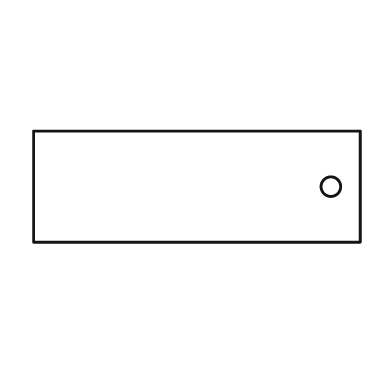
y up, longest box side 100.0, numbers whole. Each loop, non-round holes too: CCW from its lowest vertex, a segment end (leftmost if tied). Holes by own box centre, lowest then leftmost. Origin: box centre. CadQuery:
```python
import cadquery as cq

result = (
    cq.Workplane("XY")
    .moveTo(-50.0, -17.0)
    .lineTo(50.0, -17.0)
    .lineTo(50.0, 17.0)
    .lineTo(-50.0, 17.0)
    .close()
    .moveTo(41.0, 0.0)
    .circle(3.0)
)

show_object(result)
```